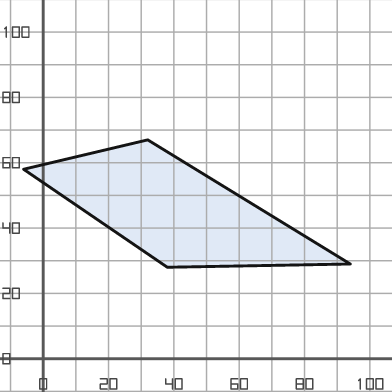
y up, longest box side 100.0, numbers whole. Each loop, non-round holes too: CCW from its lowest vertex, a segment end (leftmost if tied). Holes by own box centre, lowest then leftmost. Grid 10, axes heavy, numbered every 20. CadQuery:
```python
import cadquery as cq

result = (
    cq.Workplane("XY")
    .moveTo(38.0, 28.0)
    .lineTo(94.0, 29.0)
    .lineTo(32.0, 67.0)
    .lineTo(-6.0, 58.0)
    .close()
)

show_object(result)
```